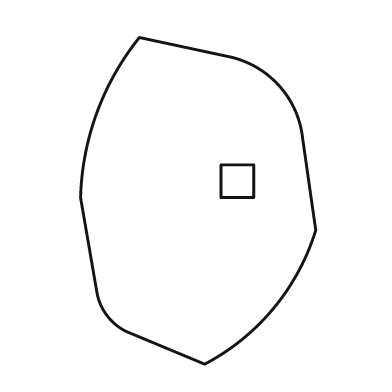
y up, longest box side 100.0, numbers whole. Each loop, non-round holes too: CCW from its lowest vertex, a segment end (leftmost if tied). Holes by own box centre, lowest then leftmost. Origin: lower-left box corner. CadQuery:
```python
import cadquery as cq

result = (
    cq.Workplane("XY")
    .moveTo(38.0, 0.0)
    .threePointArc((59.0, 17.0), (72.0, 41.0))
    .lineTo(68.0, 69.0)
    .threePointArc((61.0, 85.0), (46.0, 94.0))
    .lineTo(18.0, 100.0)
    .threePointArc((5.0, 77.0), (0.0, 51.0))
    .lineTo(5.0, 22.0)
    .threePointArc((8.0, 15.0), (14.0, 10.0))
    .close()
    .moveTo(43.0, 51.0)
    .lineTo(53.0, 51.0)
    .lineTo(53.0, 61.0)
    .lineTo(43.0, 61.0)
    .close()
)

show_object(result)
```